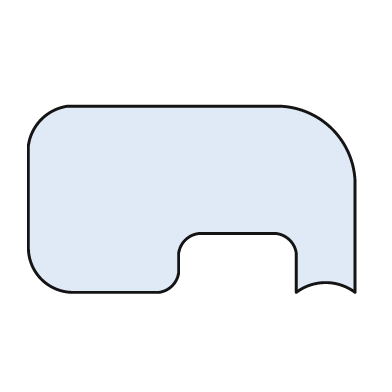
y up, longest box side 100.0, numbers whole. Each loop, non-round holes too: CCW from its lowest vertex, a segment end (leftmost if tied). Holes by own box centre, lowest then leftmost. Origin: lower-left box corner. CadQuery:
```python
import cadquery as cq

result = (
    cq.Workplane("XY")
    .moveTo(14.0, 0.0)
    .lineTo(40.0, 0.0)
    .threePointArc((44.0, 2.0), (46.0, 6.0))
    .lineTo(46.0, 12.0)
    .threePointArc((48.0, 16.0), (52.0, 18.0))
    .lineTo(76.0, 18.0)
    .threePointArc((80.0, 16.0), (82.0, 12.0))
    .lineTo(82.0, 0.0)
    .threePointArc((91.0, 3.0), (100.0, 0.0))
    .lineTo(100.0, 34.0)
    .threePointArc((93.0, 50.0), (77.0, 57.0))
    .lineTo(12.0, 57.0)
    .threePointArc((4.0, 53.0), (0.0, 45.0))
    .lineTo(0.0, 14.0)
    .threePointArc((4.0, 4.0), (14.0, 0.0))
    .close()
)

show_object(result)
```